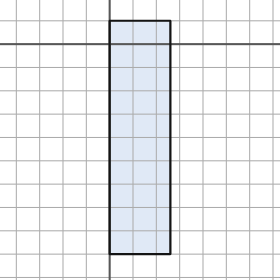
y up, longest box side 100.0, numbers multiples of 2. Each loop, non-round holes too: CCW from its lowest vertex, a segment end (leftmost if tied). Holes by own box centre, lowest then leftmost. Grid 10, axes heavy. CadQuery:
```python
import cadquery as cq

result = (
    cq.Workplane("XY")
    .moveTo(0.0, -90.0)
    .lineTo(26.0, -90.0)
    .lineTo(26.0, 10.0)
    .lineTo(0.0, 10.0)
    .close()
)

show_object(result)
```